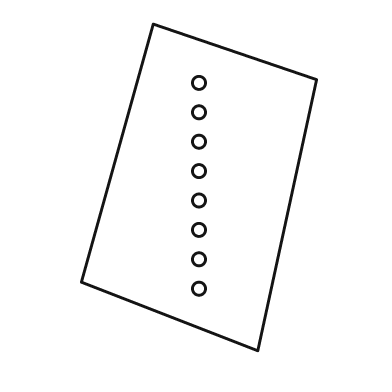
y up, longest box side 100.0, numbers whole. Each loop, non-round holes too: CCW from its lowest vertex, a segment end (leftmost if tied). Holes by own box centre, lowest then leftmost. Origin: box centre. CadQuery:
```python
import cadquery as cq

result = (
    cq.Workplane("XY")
    .moveTo(18.0, -50.0)
    .lineTo(36.0, 33.0)
    .lineTo(-14.0, 50.0)
    .lineTo(-36.0, -29.0)
    .close()
    .moveTo(0.0, -31.0)
    .circle(2.0)
    .moveTo(0.0, -22.0)
    .circle(2.0)
    .moveTo(0.0, -13.0)
    .circle(2.0)
    .moveTo(0.0, -4.0)
    .circle(2.0)
    .moveTo(0.0, 5.0)
    .circle(2.0)
    .moveTo(0.0, 14.0)
    .circle(2.0)
    .moveTo(0.0, 23.0)
    .circle(2.0)
    .moveTo(0.0, 32.0)
    .circle(2.0)
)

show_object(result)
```